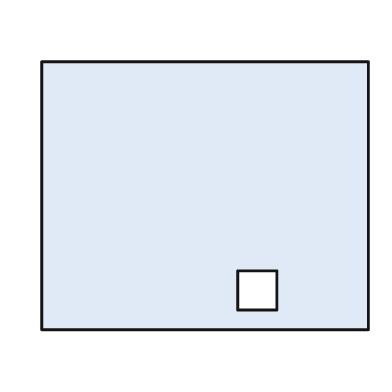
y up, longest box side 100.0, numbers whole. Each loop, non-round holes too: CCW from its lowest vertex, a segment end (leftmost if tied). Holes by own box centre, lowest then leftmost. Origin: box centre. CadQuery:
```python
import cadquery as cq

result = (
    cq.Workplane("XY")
    .moveTo(-50.0, -41.0)
    .lineTo(50.0, -41.0)
    .lineTo(50.0, 41.0)
    .lineTo(-50.0, 41.0)
    .close()
    .moveTo(10.0, -35.0)
    .lineTo(22.0, -35.0)
    .lineTo(22.0, -23.0)
    .lineTo(10.0, -23.0)
    .close()
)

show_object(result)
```